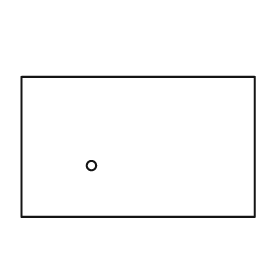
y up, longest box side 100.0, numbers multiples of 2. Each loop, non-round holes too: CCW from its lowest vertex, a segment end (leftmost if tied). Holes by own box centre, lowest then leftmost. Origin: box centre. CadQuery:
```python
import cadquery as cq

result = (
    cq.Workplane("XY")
    .moveTo(-50.0, -30.0)
    .lineTo(50.0, -30.0)
    .lineTo(50.0, 30.0)
    .lineTo(-50.0, 30.0)
    .close()
    .moveTo(-20.0, -8.0)
    .circle(2.0)
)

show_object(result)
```